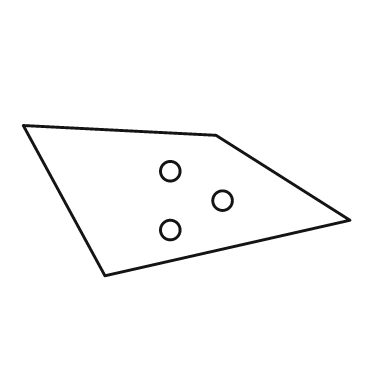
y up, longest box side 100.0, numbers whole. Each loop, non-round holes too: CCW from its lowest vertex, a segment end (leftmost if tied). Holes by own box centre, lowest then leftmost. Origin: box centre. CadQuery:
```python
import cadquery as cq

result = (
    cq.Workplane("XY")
    .moveTo(-25.0, -23.0)
    .lineTo(50.0, -6.0)
    .lineTo(9.0, 20.0)
    .lineTo(-50.0, 23.0)
    .close()
    .moveTo(-5.0, -9.0)
    .circle(3.0)
    .moveTo(11.0, 0.0)
    .circle(3.0)
    .moveTo(-5.0, 9.0)
    .circle(3.0)
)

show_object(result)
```